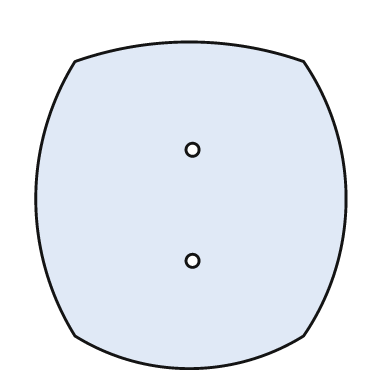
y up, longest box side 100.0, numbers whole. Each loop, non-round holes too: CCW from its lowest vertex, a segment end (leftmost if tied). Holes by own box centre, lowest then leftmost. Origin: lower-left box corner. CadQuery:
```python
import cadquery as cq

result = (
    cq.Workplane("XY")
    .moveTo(12.0, 10.0)
    .threePointArc((47.0, 0.0), (82.0, 10.0))
    .threePointArc((95.0, 52.0), (82.0, 94.0))
    .threePointArc((47.0, 100.0), (12.0, 94.0))
    .threePointArc((0.0, 52.0), (12.0, 10.0))
    .close()
    .moveTo(48.0, 33.0)
    .circle(2.0)
    .moveTo(48.0, 67.0)
    .circle(2.0)
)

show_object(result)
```